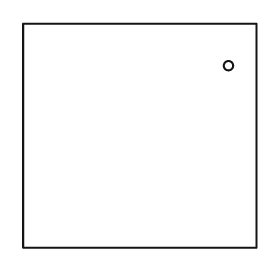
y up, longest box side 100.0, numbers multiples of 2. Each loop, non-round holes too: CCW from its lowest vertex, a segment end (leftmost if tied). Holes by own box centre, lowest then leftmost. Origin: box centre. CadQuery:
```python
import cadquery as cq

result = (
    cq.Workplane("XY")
    .moveTo(-50.0, -48.0)
    .lineTo(50.0, -48.0)
    .lineTo(50.0, 48.0)
    .lineTo(-50.0, 48.0)
    .close()
    .moveTo(38.0, 30.0)
    .circle(2.0)
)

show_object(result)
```